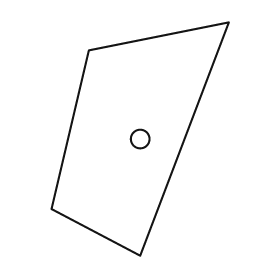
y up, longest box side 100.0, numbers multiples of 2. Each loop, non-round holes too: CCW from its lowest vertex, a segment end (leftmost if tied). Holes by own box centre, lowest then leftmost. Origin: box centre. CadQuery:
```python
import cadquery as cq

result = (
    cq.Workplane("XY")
    .moveTo(0.0, -50.0)
    .lineTo(38.0, 50.0)
    .lineTo(-22.0, 38.0)
    .lineTo(-38.0, -30.0)
    .close()
    .moveTo(0.0, 0.0)
    .circle(4.0)
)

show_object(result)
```